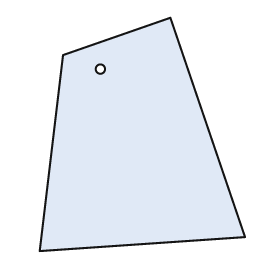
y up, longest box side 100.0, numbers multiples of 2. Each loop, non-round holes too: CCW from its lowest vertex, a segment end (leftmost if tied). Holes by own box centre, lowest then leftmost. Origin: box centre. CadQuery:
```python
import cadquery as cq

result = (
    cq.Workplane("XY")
    .moveTo(-44.0, -50.0)
    .lineTo(44.0, -44.0)
    .lineTo(12.0, 50.0)
    .lineTo(-34.0, 34.0)
    .close()
    .moveTo(-18.0, 28.0)
    .circle(2.0)
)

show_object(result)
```